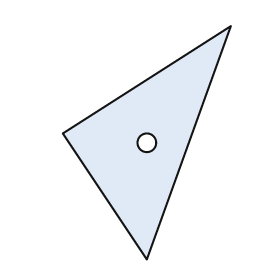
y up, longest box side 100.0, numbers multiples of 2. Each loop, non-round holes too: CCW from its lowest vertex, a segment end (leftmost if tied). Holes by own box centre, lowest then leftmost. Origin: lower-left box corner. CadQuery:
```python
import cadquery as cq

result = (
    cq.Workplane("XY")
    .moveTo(36.0, 0.0)
    .lineTo(72.0, 100.0)
    .lineTo(0.0, 54.0)
    .close()
    .moveTo(36.0, 50.0)
    .circle(4.0)
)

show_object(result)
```